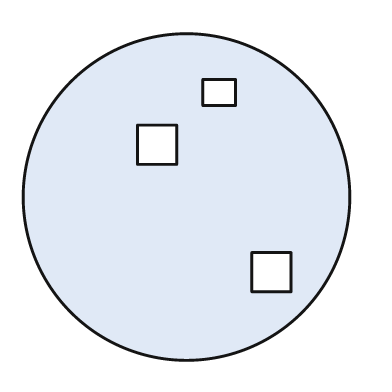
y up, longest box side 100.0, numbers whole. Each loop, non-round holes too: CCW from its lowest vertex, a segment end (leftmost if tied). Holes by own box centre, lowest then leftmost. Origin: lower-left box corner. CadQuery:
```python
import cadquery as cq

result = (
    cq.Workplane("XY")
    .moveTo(50.0, 50.0)
    .circle(50.0)
    .moveTo(70.0, 21.0)
    .lineTo(82.0, 21.0)
    .lineTo(82.0, 33.0)
    .lineTo(70.0, 33.0)
    .close()
    .moveTo(35.0, 60.0)
    .lineTo(47.0, 60.0)
    .lineTo(47.0, 72.0)
    .lineTo(35.0, 72.0)
    .close()
    .moveTo(55.0, 78.0)
    .lineTo(65.0, 78.0)
    .lineTo(65.0, 86.0)
    .lineTo(55.0, 86.0)
    .close()
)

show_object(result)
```